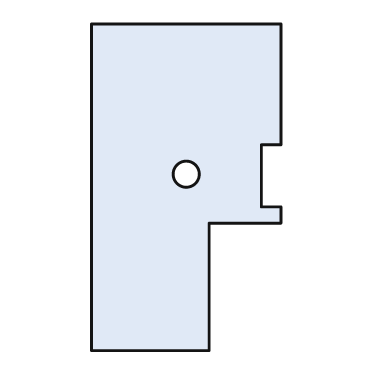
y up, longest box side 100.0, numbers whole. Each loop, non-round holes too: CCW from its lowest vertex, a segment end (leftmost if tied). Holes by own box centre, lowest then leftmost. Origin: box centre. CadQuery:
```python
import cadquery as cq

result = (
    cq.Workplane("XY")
    .moveTo(-29.0, -50.0)
    .lineTo(7.0, -50.0)
    .lineTo(7.0, -11.0)
    .lineTo(29.0, -11.0)
    .lineTo(29.0, -6.0)
    .lineTo(23.0, -6.0)
    .lineTo(23.0, 13.0)
    .lineTo(29.0, 13.0)
    .lineTo(29.0, 50.0)
    .lineTo(-29.0, 50.0)
    .close()
    .moveTo(0.0, 4.0)
    .circle(4.0)
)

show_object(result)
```